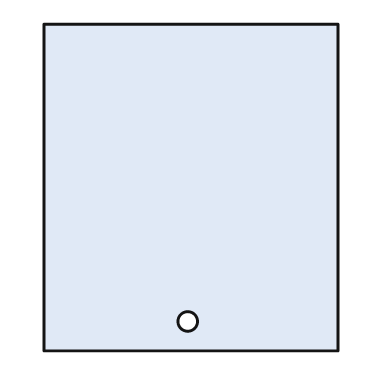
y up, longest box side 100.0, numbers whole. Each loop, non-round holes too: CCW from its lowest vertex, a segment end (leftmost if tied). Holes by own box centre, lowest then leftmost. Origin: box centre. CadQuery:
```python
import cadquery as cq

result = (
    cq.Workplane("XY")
    .moveTo(-45.0, -50.0)
    .lineTo(45.0, -50.0)
    .lineTo(45.0, 50.0)
    .lineTo(-45.0, 50.0)
    .close()
    .moveTo(-1.0, -41.0)
    .circle(3.0)
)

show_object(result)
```